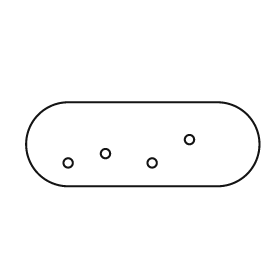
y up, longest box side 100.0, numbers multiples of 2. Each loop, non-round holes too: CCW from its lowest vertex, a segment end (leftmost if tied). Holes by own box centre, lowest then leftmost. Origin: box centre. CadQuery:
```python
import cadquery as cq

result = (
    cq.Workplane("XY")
    .moveTo(-32.0, -18.0)
    .lineTo(32.0, -18.0)
    .threePointArc((50.0, 0.0), (32.0, 18.0))
    .lineTo(-32.0, 18.0)
    .threePointArc((-50.0, 0.0), (-32.0, -18.0))
    .close()
    .moveTo(-32.0, -8.0)
    .circle(2.0)
    .moveTo(4.0, -8.0)
    .circle(2.0)
    .moveTo(-16.0, -4.0)
    .circle(2.0)
    .moveTo(20.0, 2.0)
    .circle(2.0)
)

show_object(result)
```